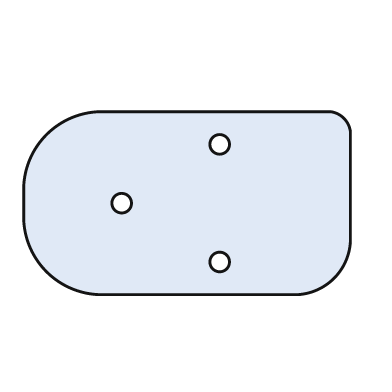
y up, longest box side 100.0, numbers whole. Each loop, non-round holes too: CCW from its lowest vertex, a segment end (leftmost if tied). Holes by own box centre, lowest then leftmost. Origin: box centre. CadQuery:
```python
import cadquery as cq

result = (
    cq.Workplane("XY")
    .moveTo(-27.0, -28.0)
    .lineTo(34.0, -28.0)
    .threePointArc((45.0, -23.0), (50.0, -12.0))
    .lineTo(50.0, 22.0)
    .threePointArc((48.0, 26.0), (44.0, 28.0))
    .lineTo(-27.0, 28.0)
    .threePointArc((-43.0, 21.0), (-50.0, 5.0))
    .lineTo(-50.0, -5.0)
    .threePointArc((-43.0, -21.0), (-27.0, -28.0))
    .close()
    .moveTo(10.0, -18.0)
    .circle(3.0)
    .moveTo(-20.0, 0.0)
    .circle(3.0)
    .moveTo(10.0, 18.0)
    .circle(3.0)
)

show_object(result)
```